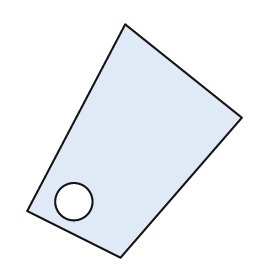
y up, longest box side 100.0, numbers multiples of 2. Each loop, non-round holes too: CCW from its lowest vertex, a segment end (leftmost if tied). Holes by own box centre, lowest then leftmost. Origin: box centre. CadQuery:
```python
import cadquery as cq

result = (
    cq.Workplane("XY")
    .moveTo(-6.0, -50.0)
    .lineTo(46.0, 10.0)
    .lineTo(-4.0, 50.0)
    .lineTo(-46.0, -30.0)
    .close()
    .moveTo(-26.0, -26.0)
    .circle(8.0)
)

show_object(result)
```